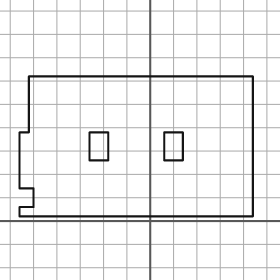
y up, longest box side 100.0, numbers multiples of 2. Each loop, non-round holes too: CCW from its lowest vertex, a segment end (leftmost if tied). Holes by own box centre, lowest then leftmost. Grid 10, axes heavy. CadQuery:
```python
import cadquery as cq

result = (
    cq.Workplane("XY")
    .moveTo(-56.0, 2.0)
    .lineTo(44.0, 2.0)
    .lineTo(44.0, 62.0)
    .lineTo(-52.0, 62.0)
    .lineTo(-52.0, 38.0)
    .lineTo(-56.0, 38.0)
    .lineTo(-56.0, 14.0)
    .lineTo(-50.0, 14.0)
    .lineTo(-50.0, 6.0)
    .lineTo(-56.0, 6.0)
    .close()
    .moveTo(-26.0, 26.0)
    .lineTo(-18.0, 26.0)
    .lineTo(-18.0, 38.0)
    .lineTo(-26.0, 38.0)
    .close()
    .moveTo(6.0, 26.0)
    .lineTo(14.0, 26.0)
    .lineTo(14.0, 38.0)
    .lineTo(6.0, 38.0)
    .close()
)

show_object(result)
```